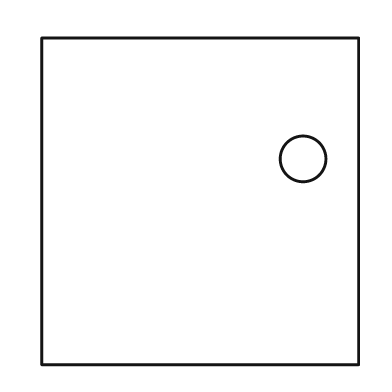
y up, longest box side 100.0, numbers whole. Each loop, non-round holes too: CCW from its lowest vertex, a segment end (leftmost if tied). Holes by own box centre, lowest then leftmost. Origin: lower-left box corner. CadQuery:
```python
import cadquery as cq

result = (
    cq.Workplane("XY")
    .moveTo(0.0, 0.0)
    .lineTo(97.0, 0.0)
    .lineTo(97.0, 100.0)
    .lineTo(0.0, 100.0)
    .close()
    .moveTo(80.0, 63.0)
    .circle(7.0)
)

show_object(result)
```